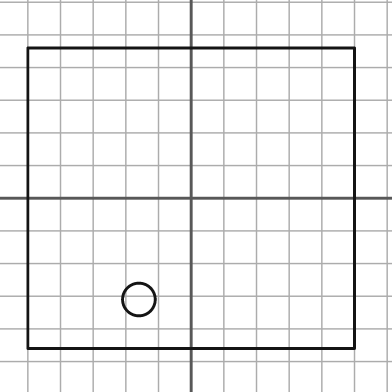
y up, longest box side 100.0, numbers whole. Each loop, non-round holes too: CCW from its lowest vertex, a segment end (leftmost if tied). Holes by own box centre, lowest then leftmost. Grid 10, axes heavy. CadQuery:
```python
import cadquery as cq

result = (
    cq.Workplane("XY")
    .moveTo(-50.0, -46.0)
    .lineTo(50.0, -46.0)
    .lineTo(50.0, 46.0)
    .lineTo(-50.0, 46.0)
    .close()
    .moveTo(-16.0, -31.0)
    .circle(5.0)
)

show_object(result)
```